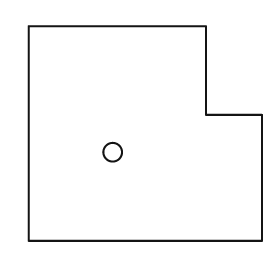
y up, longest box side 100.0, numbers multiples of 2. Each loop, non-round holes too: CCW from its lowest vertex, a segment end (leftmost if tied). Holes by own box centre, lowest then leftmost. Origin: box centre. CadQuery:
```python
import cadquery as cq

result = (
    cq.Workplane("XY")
    .moveTo(-50.0, -46.0)
    .lineTo(50.0, -46.0)
    .lineTo(50.0, 8.0)
    .lineTo(26.0, 8.0)
    .lineTo(26.0, 46.0)
    .lineTo(-50.0, 46.0)
    .close()
    .moveTo(-14.0, -8.0)
    .circle(4.0)
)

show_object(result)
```